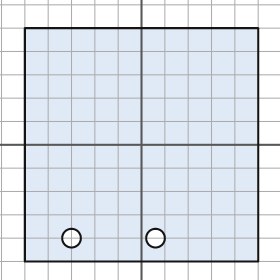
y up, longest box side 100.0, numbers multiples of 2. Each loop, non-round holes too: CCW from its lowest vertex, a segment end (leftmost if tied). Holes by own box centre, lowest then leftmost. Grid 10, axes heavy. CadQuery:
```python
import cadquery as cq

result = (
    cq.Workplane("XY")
    .moveTo(-50.0, -50.0)
    .lineTo(50.0, -50.0)
    .lineTo(50.0, 50.0)
    .lineTo(-50.0, 50.0)
    .close()
    .moveTo(-30.0, -40.0)
    .circle(4.0)
    .moveTo(6.0, -40.0)
    .circle(4.0)
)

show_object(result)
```